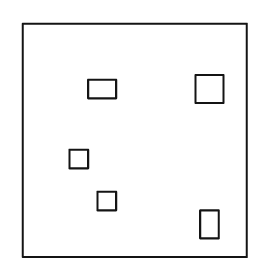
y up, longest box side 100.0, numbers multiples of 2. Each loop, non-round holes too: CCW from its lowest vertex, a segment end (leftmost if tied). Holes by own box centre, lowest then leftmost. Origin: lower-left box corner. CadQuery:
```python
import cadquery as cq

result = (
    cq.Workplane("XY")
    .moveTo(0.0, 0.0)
    .lineTo(96.0, 0.0)
    .lineTo(96.0, 100.0)
    .lineTo(0.0, 100.0)
    .close()
    .moveTo(76.0, 8.0)
    .lineTo(84.0, 8.0)
    .lineTo(84.0, 20.0)
    .lineTo(76.0, 20.0)
    .close()
    .moveTo(32.0, 20.0)
    .lineTo(40.0, 20.0)
    .lineTo(40.0, 28.0)
    .lineTo(32.0, 28.0)
    .close()
    .moveTo(20.0, 38.0)
    .lineTo(28.0, 38.0)
    .lineTo(28.0, 46.0)
    .lineTo(20.0, 46.0)
    .close()
    .moveTo(28.0, 68.0)
    .lineTo(40.0, 68.0)
    .lineTo(40.0, 76.0)
    .lineTo(28.0, 76.0)
    .close()
    .moveTo(74.0, 66.0)
    .lineTo(86.0, 66.0)
    .lineTo(86.0, 78.0)
    .lineTo(74.0, 78.0)
    .close()
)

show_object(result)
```